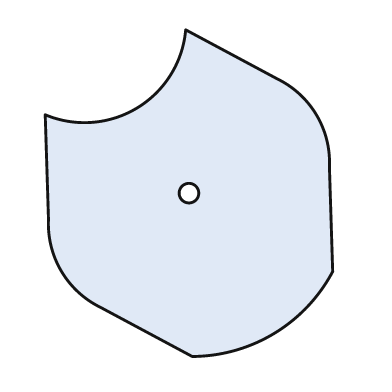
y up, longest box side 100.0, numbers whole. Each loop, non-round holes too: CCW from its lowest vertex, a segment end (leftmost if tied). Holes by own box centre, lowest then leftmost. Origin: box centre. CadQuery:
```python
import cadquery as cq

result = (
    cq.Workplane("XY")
    .moveTo(1.0, -50.0)
    .threePointArc((26.0, -43.0), (44.0, -24.0))
    .lineTo(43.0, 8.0)
    .threePointArc((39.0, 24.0), (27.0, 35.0))
    .lineTo(-1.0, 50.0)
    .threePointArc((-16.0, 26.0), (-44.0, 24.0))
    .lineTo(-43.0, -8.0)
    .threePointArc((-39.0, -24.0), (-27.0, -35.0))
    .close()
    .moveTo(0.0, 0.0)
    .circle(3.0)
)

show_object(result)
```